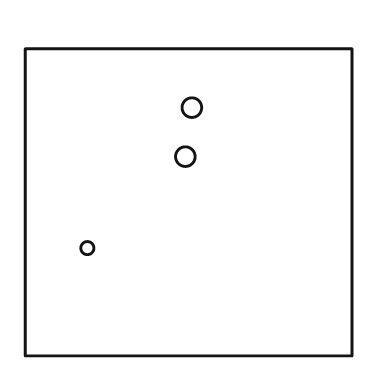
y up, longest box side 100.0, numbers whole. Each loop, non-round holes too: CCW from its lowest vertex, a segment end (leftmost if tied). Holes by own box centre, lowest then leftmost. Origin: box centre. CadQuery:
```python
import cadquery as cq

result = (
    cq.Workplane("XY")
    .moveTo(-50.0, -47.0)
    .lineTo(50.0, -47.0)
    .lineTo(50.0, 47.0)
    .lineTo(-50.0, 47.0)
    .close()
    .moveTo(-31.0, -14.0)
    .circle(2.0)
    .moveTo(-1.0, 14.0)
    .circle(3.0)
    .moveTo(1.0, 29.0)
    .circle(3.0)
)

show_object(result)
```